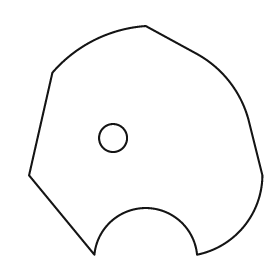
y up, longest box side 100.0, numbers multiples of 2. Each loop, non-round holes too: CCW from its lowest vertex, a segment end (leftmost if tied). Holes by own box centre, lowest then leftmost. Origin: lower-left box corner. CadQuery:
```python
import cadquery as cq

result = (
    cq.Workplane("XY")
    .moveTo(28.0, 0.0)
    .threePointArc((50.0, 20.0), (72.0, 0.0))
    .threePointArc((92.0, 12.0), (100.0, 34.0))
    .lineTo(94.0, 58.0)
    .threePointArc((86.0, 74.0), (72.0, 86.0))
    .lineTo(50.0, 98.0)
    .threePointArc((28.0, 92.0), (10.0, 78.0))
    .lineTo(0.0, 34.0)
    .close()
    .moveTo(36.0, 50.0)
    .circle(6.0)
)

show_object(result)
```